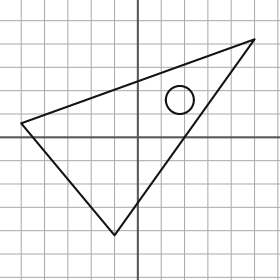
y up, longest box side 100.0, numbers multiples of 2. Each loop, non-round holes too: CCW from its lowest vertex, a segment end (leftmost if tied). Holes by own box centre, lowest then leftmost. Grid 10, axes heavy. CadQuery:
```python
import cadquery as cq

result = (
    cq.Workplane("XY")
    .moveTo(-10.0, -42.0)
    .lineTo(50.0, 42.0)
    .lineTo(-50.0, 6.0)
    .close()
    .moveTo(18.0, 16.0)
    .circle(6.0)
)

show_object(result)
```